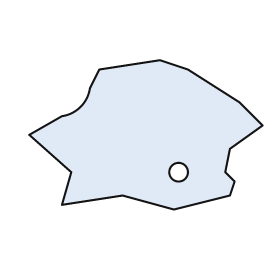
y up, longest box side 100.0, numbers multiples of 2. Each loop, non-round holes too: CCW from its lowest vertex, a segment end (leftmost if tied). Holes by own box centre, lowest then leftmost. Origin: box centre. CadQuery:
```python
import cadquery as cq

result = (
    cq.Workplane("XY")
    .moveTo(12.0, -32.0)
    .lineTo(36.0, -26.0)
    .lineTo(38.0, -20.0)
    .lineTo(34.0, -16.0)
    .lineTo(36.0, -6.0)
    .lineTo(50.0, 4.0)
    .lineTo(40.0, 14.0)
    .lineTo(18.0, 28.0)
    .lineTo(6.0, 32.0)
    .lineTo(-20.0, 28.0)
    .lineTo(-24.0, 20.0)
    .threePointArc((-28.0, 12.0), (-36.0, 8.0))
    .lineTo(-50.0, 0.0)
    .lineTo(-32.0, -16.0)
    .lineTo(-36.0, -30.0)
    .lineTo(-10.0, -26.0)
    .close()
    .moveTo(14.0, -16.0)
    .circle(4.0)
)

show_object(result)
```